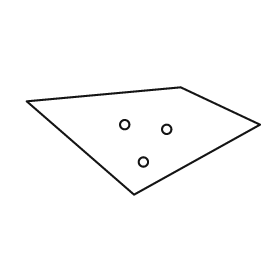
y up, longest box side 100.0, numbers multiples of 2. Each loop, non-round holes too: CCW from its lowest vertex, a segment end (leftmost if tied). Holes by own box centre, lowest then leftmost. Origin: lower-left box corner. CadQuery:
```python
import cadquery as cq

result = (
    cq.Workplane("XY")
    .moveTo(46.0, 0.0)
    .lineTo(100.0, 30.0)
    .lineTo(66.0, 46.0)
    .lineTo(0.0, 40.0)
    .close()
    .moveTo(50.0, 14.0)
    .circle(2.0)
    .moveTo(60.0, 28.0)
    .circle(2.0)
    .moveTo(42.0, 30.0)
    .circle(2.0)
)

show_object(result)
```